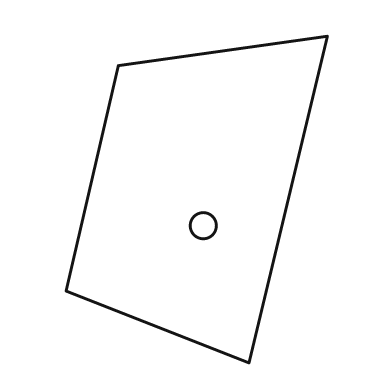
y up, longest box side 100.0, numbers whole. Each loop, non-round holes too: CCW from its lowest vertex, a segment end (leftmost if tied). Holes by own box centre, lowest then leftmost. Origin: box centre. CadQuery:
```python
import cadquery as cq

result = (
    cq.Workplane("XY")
    .moveTo(16.0, -50.0)
    .lineTo(40.0, 50.0)
    .lineTo(-24.0, 41.0)
    .lineTo(-40.0, -28.0)
    .close()
    .moveTo(2.0, -8.0)
    .circle(4.0)
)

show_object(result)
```